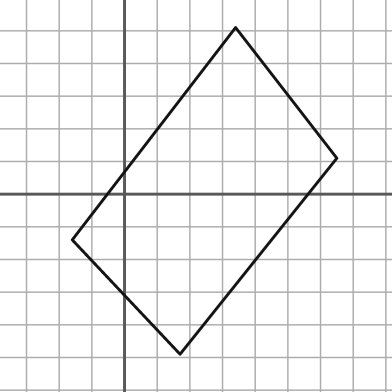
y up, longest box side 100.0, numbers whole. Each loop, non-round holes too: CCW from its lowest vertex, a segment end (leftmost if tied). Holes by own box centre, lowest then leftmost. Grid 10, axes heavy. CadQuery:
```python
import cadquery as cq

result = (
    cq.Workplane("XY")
    .moveTo(17.0, -49.0)
    .lineTo(65.0, 11.0)
    .lineTo(34.0, 51.0)
    .lineTo(-16.0, -14.0)
    .close()
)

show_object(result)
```